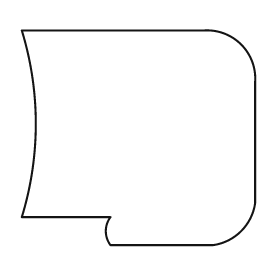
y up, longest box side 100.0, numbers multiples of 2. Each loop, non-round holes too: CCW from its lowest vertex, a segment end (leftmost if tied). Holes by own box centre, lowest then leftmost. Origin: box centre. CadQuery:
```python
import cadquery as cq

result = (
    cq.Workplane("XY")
    .moveTo(-12.0, -46.0)
    .lineTo(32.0, -46.0)
    .threePointArc((44.0, -40.0), (50.0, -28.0))
    .lineTo(50.0, 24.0)
    .threePointArc((44.0, 40.0), (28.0, 46.0))
    .lineTo(-50.0, 46.0)
    .threePointArc((-44.0, 6.0), (-50.0, -34.0))
    .lineTo(-12.0, -34.0)
    .threePointArc((-14.0, -40.0), (-12.0, -46.0))
    .close()
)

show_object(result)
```